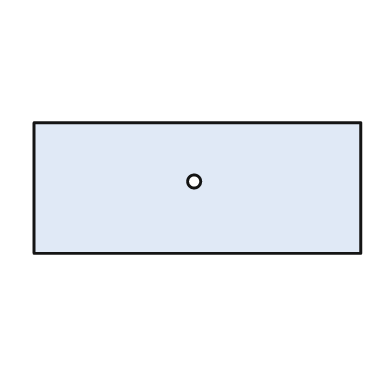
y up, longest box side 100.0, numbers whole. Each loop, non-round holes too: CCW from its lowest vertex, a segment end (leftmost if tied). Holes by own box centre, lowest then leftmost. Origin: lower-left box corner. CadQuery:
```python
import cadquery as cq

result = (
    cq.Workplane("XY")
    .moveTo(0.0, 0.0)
    .lineTo(100.0, 0.0)
    .lineTo(100.0, 40.0)
    .lineTo(0.0, 40.0)
    .close()
    .moveTo(49.0, 22.0)
    .circle(2.0)
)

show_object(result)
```